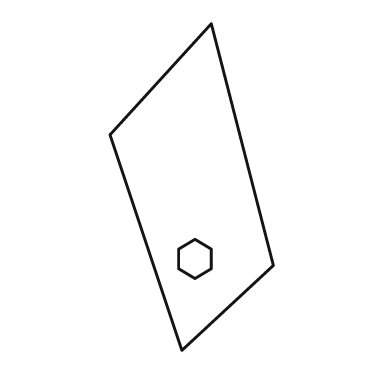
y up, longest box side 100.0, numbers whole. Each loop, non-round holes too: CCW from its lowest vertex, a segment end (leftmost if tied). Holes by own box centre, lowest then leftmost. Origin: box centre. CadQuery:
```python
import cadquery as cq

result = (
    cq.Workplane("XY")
    .moveTo(-3.0, -50.0)
    .lineTo(25.0, -24.0)
    .lineTo(6.0, 50.0)
    .lineTo(-25.0, 16.0)
    .close()
    .moveTo(1.0, -28.0)
    .lineTo(6.0, -25.0)
    .lineTo(6.0, -19.0)
    .lineTo(1.0, -16.0)
    .lineTo(-4.0, -19.0)
    .lineTo(-4.0, -25.0)
    .close()
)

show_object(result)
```